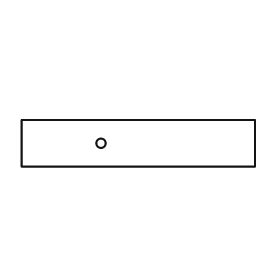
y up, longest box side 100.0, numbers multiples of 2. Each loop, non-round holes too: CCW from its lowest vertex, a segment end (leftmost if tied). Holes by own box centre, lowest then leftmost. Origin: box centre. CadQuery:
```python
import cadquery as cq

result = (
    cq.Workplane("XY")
    .moveTo(-50.0, -10.0)
    .lineTo(50.0, -10.0)
    .lineTo(50.0, 10.0)
    .lineTo(-50.0, 10.0)
    .close()
    .moveTo(-16.0, 0.0)
    .circle(2.0)
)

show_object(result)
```